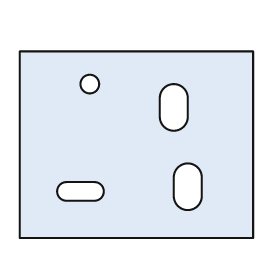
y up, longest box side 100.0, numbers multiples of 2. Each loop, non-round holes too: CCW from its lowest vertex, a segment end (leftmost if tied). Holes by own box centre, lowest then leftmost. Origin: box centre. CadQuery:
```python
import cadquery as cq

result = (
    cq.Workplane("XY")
    .moveTo(-50.0, -40.0)
    .lineTo(50.0, -40.0)
    .lineTo(50.0, 40.0)
    .lineTo(-50.0, 40.0)
    .close()
    .moveTo(-30.0, -24.0)
    .lineTo(-18.0, -24.0)
    .threePointArc((-14.0, -20.0), (-18.0, -16.0))
    .lineTo(-30.0, -16.0)
    .threePointArc((-34.0, -20.0), (-30.0, -24.0))
    .close()
    .moveTo(16.0, -22.0)
    .threePointArc((22.0, -28.0), (28.0, -22.0))
    .lineTo(28.0, -14.0)
    .threePointArc((22.0, -8.0), (16.0, -14.0))
    .close()
    .moveTo(10.0, 12.0)
    .threePointArc((16.0, 6.0), (22.0, 12.0))
    .lineTo(22.0, 20.0)
    .threePointArc((16.0, 26.0), (10.0, 20.0))
    .close()
    .moveTo(-20.0, 26.0)
    .circle(4.0)
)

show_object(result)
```